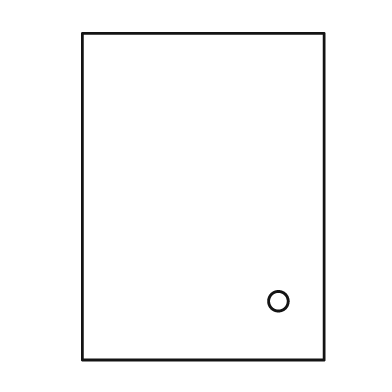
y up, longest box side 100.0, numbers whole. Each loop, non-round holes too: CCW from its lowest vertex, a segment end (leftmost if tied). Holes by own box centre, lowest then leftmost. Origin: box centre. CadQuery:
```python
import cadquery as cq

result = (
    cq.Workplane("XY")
    .moveTo(-37.0, -50.0)
    .lineTo(37.0, -50.0)
    .lineTo(37.0, 50.0)
    .lineTo(-37.0, 50.0)
    .close()
    .moveTo(23.0, -32.0)
    .circle(3.0)
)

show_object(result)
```